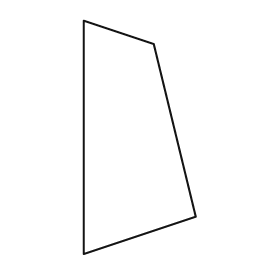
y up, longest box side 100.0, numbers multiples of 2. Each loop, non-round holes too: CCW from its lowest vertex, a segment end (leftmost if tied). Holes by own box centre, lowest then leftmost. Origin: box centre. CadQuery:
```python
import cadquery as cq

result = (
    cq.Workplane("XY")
    .moveTo(-24.0, -50.0)
    .lineTo(24.0, -34.0)
    .lineTo(6.0, 40.0)
    .lineTo(-24.0, 50.0)
    .close()
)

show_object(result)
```